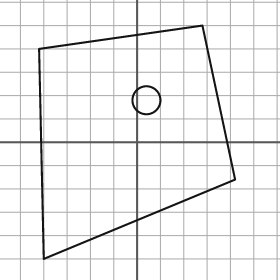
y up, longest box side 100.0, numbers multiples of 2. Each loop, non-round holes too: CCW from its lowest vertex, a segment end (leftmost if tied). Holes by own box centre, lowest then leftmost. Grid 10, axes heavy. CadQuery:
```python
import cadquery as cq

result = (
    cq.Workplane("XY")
    .moveTo(-40.0, -50.0)
    .lineTo(42.0, -16.0)
    .lineTo(28.0, 50.0)
    .lineTo(-42.0, 40.0)
    .close()
    .moveTo(4.0, 18.0)
    .circle(6.0)
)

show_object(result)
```